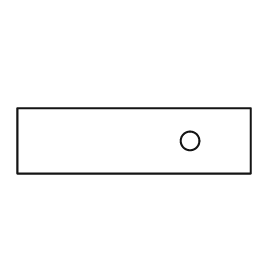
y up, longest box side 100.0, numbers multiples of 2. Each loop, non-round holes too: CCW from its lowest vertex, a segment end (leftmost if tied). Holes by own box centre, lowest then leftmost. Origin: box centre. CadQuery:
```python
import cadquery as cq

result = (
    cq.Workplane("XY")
    .moveTo(-50.0, -14.0)
    .lineTo(50.0, -14.0)
    .lineTo(50.0, 14.0)
    .lineTo(-50.0, 14.0)
    .close()
    .moveTo(24.0, 0.0)
    .circle(4.0)
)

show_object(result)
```